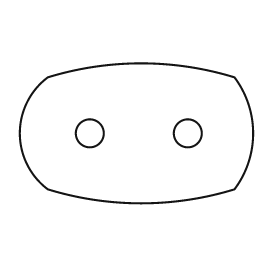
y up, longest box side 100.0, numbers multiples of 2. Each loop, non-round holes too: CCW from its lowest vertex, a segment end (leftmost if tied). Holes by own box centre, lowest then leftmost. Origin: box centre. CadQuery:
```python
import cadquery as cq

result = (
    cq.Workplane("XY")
    .moveTo(-38.0, -24.0)
    .threePointArc((2.0, -30.0), (42.0, -24.0))
    .threePointArc((50.0, 0.0), (42.0, 24.0))
    .threePointArc((2.0, 30.0), (-38.0, 24.0))
    .threePointArc((-50.0, 0.0), (-38.0, -24.0))
    .close()
    .moveTo(-20.0, 0.0)
    .circle(6.0)
    .moveTo(22.0, 0.0)
    .circle(6.0)
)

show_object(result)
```